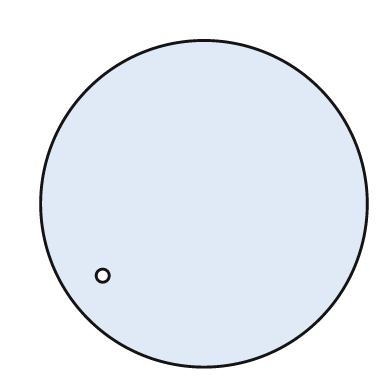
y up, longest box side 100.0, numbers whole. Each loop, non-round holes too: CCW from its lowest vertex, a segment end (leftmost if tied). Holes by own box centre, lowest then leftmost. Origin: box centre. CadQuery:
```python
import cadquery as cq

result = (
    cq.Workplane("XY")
    .moveTo(0.0, 0.0)
    .circle(50.0)
    .moveTo(-31.0, -22.0)
    .circle(2.0)
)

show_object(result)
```